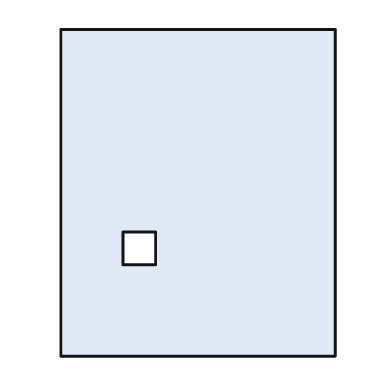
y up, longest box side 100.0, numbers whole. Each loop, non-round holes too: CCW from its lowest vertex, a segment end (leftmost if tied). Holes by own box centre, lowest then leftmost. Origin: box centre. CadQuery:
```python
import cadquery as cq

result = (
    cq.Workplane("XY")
    .moveTo(-42.0, -50.0)
    .lineTo(42.0, -50.0)
    .lineTo(42.0, 50.0)
    .lineTo(-42.0, 50.0)
    .close()
    .moveTo(-23.0, -22.0)
    .lineTo(-13.0, -22.0)
    .lineTo(-13.0, -12.0)
    .lineTo(-23.0, -12.0)
    .close()
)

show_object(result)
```